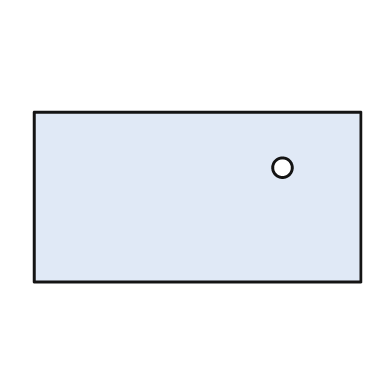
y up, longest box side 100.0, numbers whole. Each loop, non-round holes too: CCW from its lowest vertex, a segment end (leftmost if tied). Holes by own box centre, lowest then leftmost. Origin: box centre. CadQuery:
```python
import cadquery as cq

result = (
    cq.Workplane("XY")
    .moveTo(-50.0, -26.0)
    .lineTo(50.0, -26.0)
    .lineTo(50.0, 26.0)
    .lineTo(-50.0, 26.0)
    .close()
    .moveTo(26.0, 9.0)
    .circle(3.0)
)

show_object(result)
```